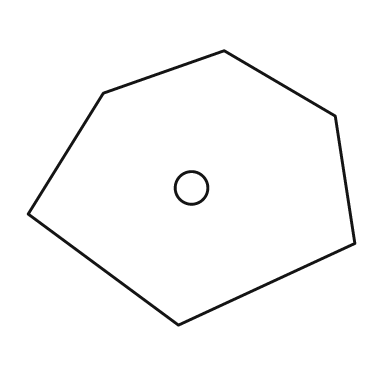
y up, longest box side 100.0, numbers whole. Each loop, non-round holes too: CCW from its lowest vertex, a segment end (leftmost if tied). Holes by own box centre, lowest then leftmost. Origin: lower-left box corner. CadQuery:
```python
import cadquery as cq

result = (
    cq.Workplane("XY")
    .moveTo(46.0, 0.0)
    .lineTo(100.0, 25.0)
    .lineTo(94.0, 64.0)
    .lineTo(60.0, 84.0)
    .lineTo(23.0, 71.0)
    .lineTo(0.0, 34.0)
    .close()
    .moveTo(50.0, 42.0)
    .circle(5.0)
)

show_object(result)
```